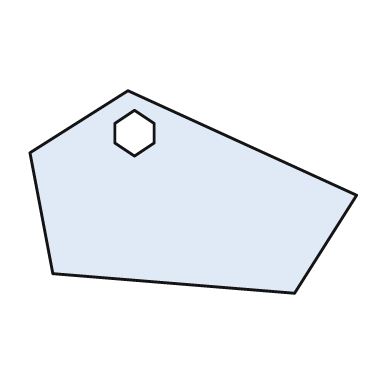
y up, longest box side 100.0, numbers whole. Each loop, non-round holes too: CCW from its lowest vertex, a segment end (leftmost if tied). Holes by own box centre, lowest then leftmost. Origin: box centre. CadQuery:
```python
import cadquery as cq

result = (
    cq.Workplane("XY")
    .moveTo(31.0, -31.0)
    .lineTo(50.0, -1.0)
    .lineTo(-20.0, 31.0)
    .lineTo(-50.0, 12.0)
    .lineTo(-43.0, -25.0)
    .close()
    .moveTo(-18.0, 11.0)
    .lineTo(-12.0, 15.0)
    .lineTo(-12.0, 21.0)
    .lineTo(-18.0, 25.0)
    .lineTo(-24.0, 21.0)
    .lineTo(-24.0, 15.0)
    .close()
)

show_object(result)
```